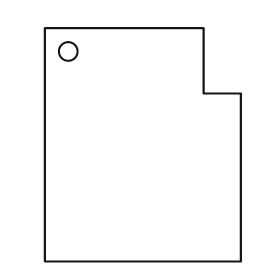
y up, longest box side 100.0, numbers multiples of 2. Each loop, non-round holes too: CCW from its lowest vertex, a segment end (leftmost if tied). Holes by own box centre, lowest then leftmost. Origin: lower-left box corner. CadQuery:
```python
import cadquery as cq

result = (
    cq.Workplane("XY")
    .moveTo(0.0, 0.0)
    .lineTo(84.0, 0.0)
    .lineTo(84.0, 72.0)
    .lineTo(68.0, 72.0)
    .lineTo(68.0, 100.0)
    .lineTo(0.0, 100.0)
    .close()
    .moveTo(10.0, 90.0)
    .circle(4.0)
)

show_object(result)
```